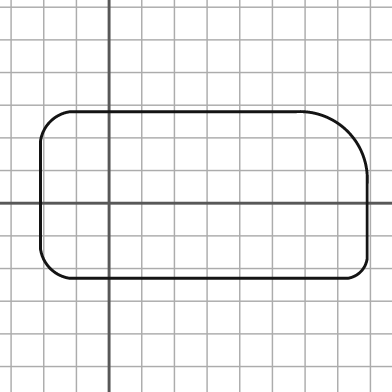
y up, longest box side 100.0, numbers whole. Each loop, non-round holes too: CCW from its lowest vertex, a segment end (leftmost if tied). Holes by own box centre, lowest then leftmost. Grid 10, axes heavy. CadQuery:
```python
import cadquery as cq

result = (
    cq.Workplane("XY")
    .moveTo(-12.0, -23.0)
    .lineTo(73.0, -23.0)
    .threePointArc((77.0, -21.0), (79.0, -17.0))
    .lineTo(79.0, 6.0)
    .threePointArc((73.0, 22.0), (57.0, 28.0))
    .lineTo(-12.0, 28.0)
    .threePointArc((-18.0, 25.0), (-21.0, 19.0))
    .lineTo(-21.0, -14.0)
    .threePointArc((-18.0, -20.0), (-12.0, -23.0))
    .close()
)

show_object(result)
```